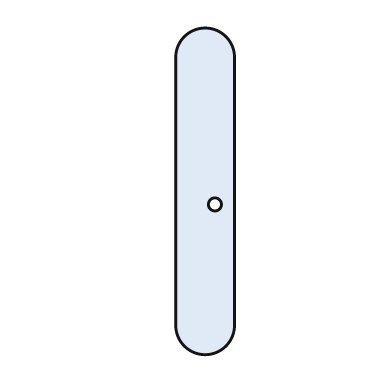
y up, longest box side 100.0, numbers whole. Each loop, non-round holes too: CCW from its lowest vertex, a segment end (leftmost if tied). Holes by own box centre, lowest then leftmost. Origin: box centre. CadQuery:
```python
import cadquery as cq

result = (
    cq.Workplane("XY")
    .moveTo(-9.0, -41.0)
    .threePointArc((0.0, -50.0), (9.0, -41.0))
    .lineTo(9.0, 41.0)
    .threePointArc((0.0, 50.0), (-9.0, 41.0))
    .close()
    .moveTo(3.0, -4.0)
    .circle(2.0)
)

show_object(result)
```